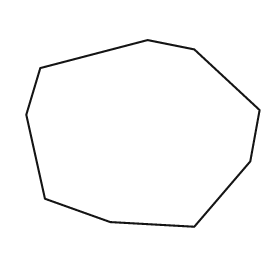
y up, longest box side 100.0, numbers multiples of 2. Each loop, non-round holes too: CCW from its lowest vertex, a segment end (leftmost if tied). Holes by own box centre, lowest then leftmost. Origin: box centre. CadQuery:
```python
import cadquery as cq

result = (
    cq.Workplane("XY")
    .moveTo(22.0, -40.0)
    .lineTo(46.0, -12.0)
    .lineTo(50.0, 10.0)
    .lineTo(22.0, 36.0)
    .lineTo(2.0, 40.0)
    .lineTo(-44.0, 28.0)
    .lineTo(-50.0, 8.0)
    .lineTo(-42.0, -28.0)
    .lineTo(-14.0, -38.0)
    .close()
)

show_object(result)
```